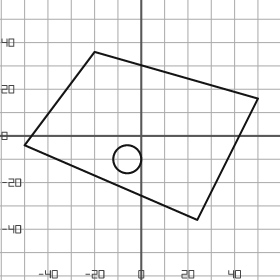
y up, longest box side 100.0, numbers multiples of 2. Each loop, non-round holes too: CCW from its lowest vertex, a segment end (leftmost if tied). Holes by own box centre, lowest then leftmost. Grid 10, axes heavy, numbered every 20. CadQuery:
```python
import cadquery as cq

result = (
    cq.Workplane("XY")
    .moveTo(24.0, -36.0)
    .lineTo(50.0, 16.0)
    .lineTo(-20.0, 36.0)
    .lineTo(-50.0, -4.0)
    .close()
    .moveTo(-6.0, -10.0)
    .circle(6.0)
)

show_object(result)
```